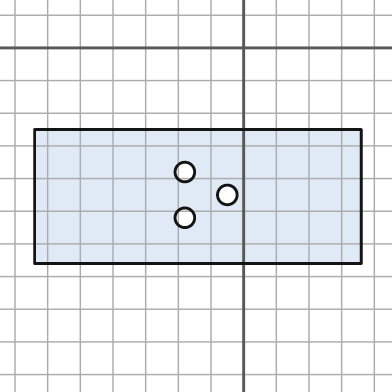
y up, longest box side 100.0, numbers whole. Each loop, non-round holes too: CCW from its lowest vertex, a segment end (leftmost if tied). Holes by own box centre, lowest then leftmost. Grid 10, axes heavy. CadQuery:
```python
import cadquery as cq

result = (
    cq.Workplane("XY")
    .moveTo(-64.0, -66.0)
    .lineTo(36.0, -66.0)
    .lineTo(36.0, -25.0)
    .lineTo(-64.0, -25.0)
    .close()
    .moveTo(-18.0, -52.0)
    .circle(3.0)
    .moveTo(-5.0, -45.0)
    .circle(3.0)
    .moveTo(-18.0, -38.0)
    .circle(3.0)
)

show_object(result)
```